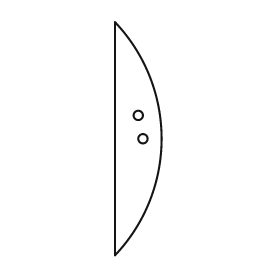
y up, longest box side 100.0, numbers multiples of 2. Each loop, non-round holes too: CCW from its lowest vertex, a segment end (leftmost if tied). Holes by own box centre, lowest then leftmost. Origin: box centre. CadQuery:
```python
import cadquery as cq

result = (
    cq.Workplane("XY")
    .moveTo(-10.0, -50.0)
    .threePointArc((10.0, 0.0), (-10.0, 50.0))
    .close()
    .moveTo(2.0, 0.0)
    .circle(2.0)
    .moveTo(0.0, 10.0)
    .circle(2.0)
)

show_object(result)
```